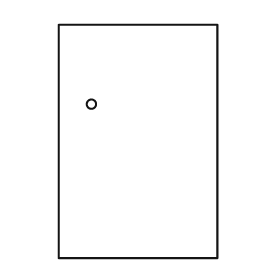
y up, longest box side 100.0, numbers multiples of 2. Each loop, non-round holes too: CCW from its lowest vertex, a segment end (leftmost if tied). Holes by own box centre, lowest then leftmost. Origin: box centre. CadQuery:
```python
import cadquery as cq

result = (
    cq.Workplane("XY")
    .moveTo(-34.0, -50.0)
    .lineTo(34.0, -50.0)
    .lineTo(34.0, 50.0)
    .lineTo(-34.0, 50.0)
    .close()
    .moveTo(-20.0, 16.0)
    .circle(2.0)
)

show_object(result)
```